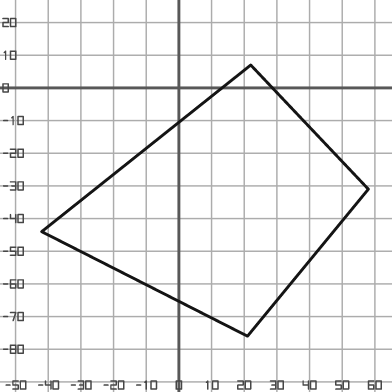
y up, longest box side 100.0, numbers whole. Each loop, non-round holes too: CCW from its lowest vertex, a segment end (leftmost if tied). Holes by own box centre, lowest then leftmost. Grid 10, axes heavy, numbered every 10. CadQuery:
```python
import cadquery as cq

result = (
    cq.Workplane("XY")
    .moveTo(21.0, -76.0)
    .lineTo(58.0, -31.0)
    .lineTo(22.0, 7.0)
    .lineTo(-42.0, -44.0)
    .close()
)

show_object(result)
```